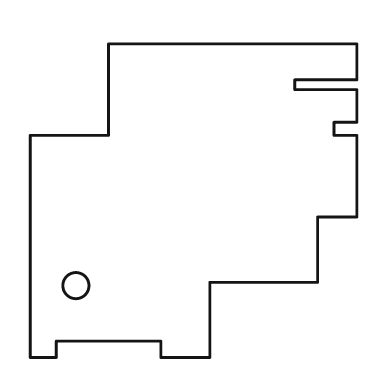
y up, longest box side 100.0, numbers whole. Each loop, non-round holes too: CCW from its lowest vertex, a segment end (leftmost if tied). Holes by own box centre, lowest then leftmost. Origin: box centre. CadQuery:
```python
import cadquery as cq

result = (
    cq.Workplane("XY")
    .moveTo(-50.0, -48.0)
    .lineTo(-42.0, -48.0)
    .lineTo(-42.0, -43.0)
    .lineTo(-10.0, -43.0)
    .lineTo(-10.0, -48.0)
    .lineTo(5.0, -48.0)
    .lineTo(5.0, -25.0)
    .lineTo(38.0, -25.0)
    .lineTo(38.0, -5.0)
    .lineTo(50.0, -5.0)
    .lineTo(50.0, 20.0)
    .lineTo(43.0, 20.0)
    .lineTo(43.0, 24.0)
    .lineTo(50.0, 24.0)
    .lineTo(50.0, 34.0)
    .lineTo(31.0, 34.0)
    .lineTo(31.0, 37.0)
    .lineTo(50.0, 37.0)
    .lineTo(50.0, 48.0)
    .lineTo(-26.0, 48.0)
    .lineTo(-26.0, 20.0)
    .lineTo(-50.0, 20.0)
    .close()
    .moveTo(-36.0, -26.0)
    .circle(4.0)
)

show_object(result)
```